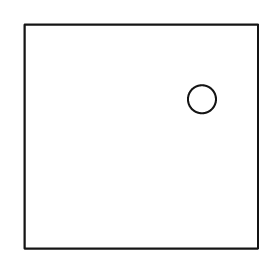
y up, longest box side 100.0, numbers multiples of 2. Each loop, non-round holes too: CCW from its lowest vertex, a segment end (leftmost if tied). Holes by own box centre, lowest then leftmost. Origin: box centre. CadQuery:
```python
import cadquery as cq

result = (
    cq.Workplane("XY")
    .moveTo(-50.0, -48.0)
    .lineTo(50.0, -48.0)
    .lineTo(50.0, 48.0)
    .lineTo(-50.0, 48.0)
    .close()
    .moveTo(26.0, 16.0)
    .circle(6.0)
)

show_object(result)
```